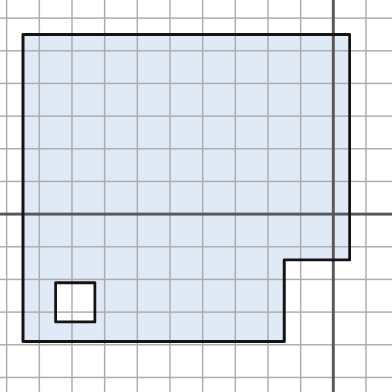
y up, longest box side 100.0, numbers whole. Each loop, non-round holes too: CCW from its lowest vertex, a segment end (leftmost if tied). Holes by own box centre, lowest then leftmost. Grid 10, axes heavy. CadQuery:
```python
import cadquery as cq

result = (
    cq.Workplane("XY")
    .moveTo(-95.0, -39.0)
    .lineTo(-15.0, -39.0)
    .lineTo(-15.0, -14.0)
    .lineTo(5.0, -14.0)
    .lineTo(5.0, 55.0)
    .lineTo(-95.0, 55.0)
    .close()
    .moveTo(-85.0, -33.0)
    .lineTo(-73.0, -33.0)
    .lineTo(-73.0, -21.0)
    .lineTo(-85.0, -21.0)
    .close()
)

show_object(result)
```